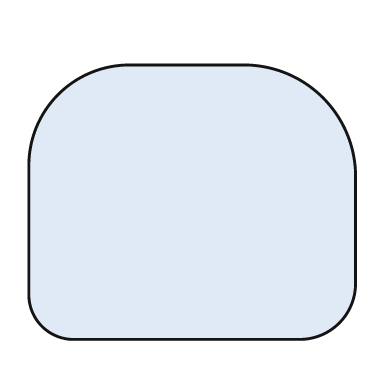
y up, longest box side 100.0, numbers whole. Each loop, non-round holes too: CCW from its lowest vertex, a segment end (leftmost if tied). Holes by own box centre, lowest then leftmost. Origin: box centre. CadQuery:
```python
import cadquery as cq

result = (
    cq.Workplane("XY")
    .moveTo(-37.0, -42.0)
    .lineTo(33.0, -42.0)
    .threePointArc((45.0, -37.0), (50.0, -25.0))
    .lineTo(50.0, 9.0)
    .threePointArc((40.0, 32.0), (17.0, 42.0))
    .lineTo(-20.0, 42.0)
    .threePointArc((-41.0, 33.0), (-50.0, 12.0))
    .lineTo(-50.0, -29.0)
    .threePointArc((-46.0, -38.0), (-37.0, -42.0))
    .close()
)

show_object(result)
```